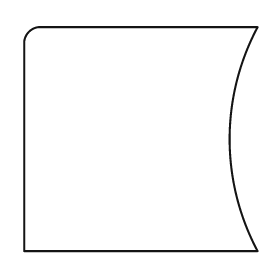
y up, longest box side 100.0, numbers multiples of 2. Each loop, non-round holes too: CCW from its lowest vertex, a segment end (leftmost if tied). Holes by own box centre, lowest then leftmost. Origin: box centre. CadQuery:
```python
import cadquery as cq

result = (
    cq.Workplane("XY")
    .moveTo(-50.0, -48.0)
    .lineTo(50.0, -48.0)
    .threePointArc((38.0, 0.0), (50.0, 48.0))
    .lineTo(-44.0, 48.0)
    .threePointArc((-48.0, 46.0), (-50.0, 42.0))
    .close()
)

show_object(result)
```